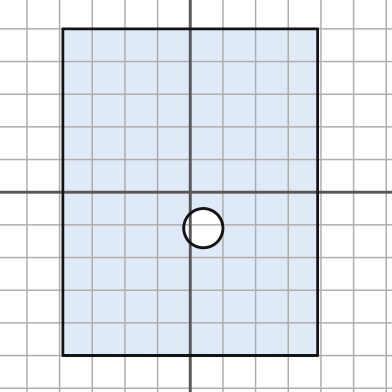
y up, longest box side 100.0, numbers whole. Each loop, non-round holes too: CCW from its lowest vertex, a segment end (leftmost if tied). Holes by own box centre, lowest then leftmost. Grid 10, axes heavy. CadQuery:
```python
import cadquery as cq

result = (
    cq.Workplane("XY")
    .moveTo(-39.0, -50.0)
    .lineTo(39.0, -50.0)
    .lineTo(39.0, 50.0)
    .lineTo(-39.0, 50.0)
    .close()
    .moveTo(4.0, -11.0)
    .circle(6.0)
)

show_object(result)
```